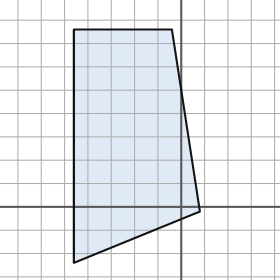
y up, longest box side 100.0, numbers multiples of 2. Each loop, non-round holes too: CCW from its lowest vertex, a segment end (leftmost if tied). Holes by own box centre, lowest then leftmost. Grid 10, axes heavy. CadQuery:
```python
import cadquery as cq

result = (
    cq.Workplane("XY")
    .moveTo(-46.0, -24.0)
    .lineTo(8.0, -2.0)
    .lineTo(-4.0, 76.0)
    .lineTo(-46.0, 76.0)
    .close()
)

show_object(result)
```